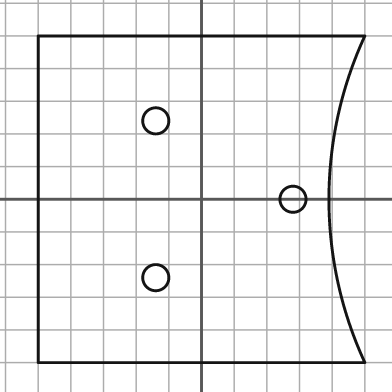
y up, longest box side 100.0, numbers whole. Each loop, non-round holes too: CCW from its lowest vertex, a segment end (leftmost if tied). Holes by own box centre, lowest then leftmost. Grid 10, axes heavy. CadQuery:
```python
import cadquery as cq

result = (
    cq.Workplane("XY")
    .moveTo(-50.0, -50.0)
    .lineTo(50.0, -50.0)
    .threePointArc((39.0, 0.0), (50.0, 50.0))
    .lineTo(-50.0, 50.0)
    .close()
    .moveTo(-14.0, -24.0)
    .circle(4.0)
    .moveTo(28.0, 0.0)
    .circle(4.0)
    .moveTo(-14.0, 24.0)
    .circle(4.0)
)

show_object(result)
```